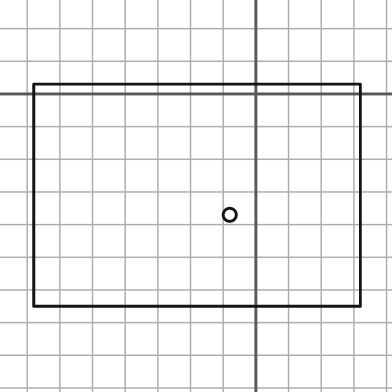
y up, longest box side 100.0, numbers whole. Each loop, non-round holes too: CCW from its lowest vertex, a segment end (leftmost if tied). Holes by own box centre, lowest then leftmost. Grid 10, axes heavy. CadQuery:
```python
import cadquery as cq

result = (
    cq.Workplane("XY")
    .moveTo(-68.0, -65.0)
    .lineTo(32.0, -65.0)
    .lineTo(32.0, 3.0)
    .lineTo(-68.0, 3.0)
    .close()
    .moveTo(-8.0, -37.0)
    .circle(2.0)
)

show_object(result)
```